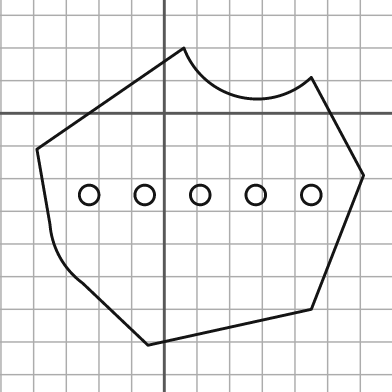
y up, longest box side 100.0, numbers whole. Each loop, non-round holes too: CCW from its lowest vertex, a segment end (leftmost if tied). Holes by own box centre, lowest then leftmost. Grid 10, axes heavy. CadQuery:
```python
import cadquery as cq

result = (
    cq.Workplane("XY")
    .moveTo(-5.0, -71.0)
    .lineTo(45.0, -60.0)
    .lineTo(61.0, -19.0)
    .lineTo(45.0, 11.0)
    .threePointArc((23.0, 5.0), (6.0, 20.0))
    .lineTo(-39.0, -11.0)
    .lineTo(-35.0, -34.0)
    .threePointArc((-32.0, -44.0), (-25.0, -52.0))
    .close()
    .moveTo(-23.0, -25.0)
    .circle(3.0)
    .moveTo(-6.0, -25.0)
    .circle(3.0)
    .moveTo(11.0, -25.0)
    .circle(3.0)
    .moveTo(28.0, -25.0)
    .circle(3.0)
    .moveTo(45.0, -25.0)
    .circle(3.0)
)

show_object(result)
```